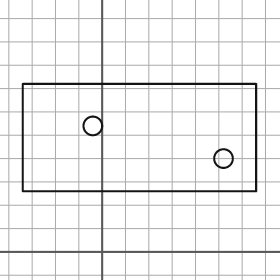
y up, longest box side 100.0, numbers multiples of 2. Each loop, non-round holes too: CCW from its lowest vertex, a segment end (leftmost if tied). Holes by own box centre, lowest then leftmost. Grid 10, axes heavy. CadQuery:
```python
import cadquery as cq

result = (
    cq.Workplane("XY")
    .moveTo(-34.0, 26.0)
    .lineTo(66.0, 26.0)
    .lineTo(66.0, 72.0)
    .lineTo(-34.0, 72.0)
    .close()
    .moveTo(52.0, 40.0)
    .circle(4.0)
    .moveTo(-4.0, 54.0)
    .circle(4.0)
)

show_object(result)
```